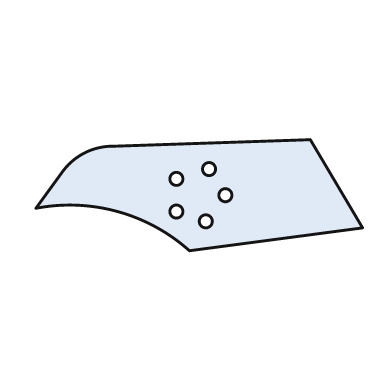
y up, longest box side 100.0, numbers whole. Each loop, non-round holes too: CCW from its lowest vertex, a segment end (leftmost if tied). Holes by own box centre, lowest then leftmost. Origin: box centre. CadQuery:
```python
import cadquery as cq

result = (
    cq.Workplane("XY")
    .moveTo(-3.0, -17.0)
    .lineTo(50.0, -10.0)
    .lineTo(34.0, 17.0)
    .lineTo(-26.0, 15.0)
    .threePointArc((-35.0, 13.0), (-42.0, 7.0))
    .lineTo(-50.0, -4.0)
    .threePointArc((-25.0, -5.0), (-3.0, -17.0))
    .close()
    .moveTo(2.0, -8.0)
    .circle(2.0)
    .moveTo(-7.0, -5.0)
    .circle(2.0)
    .moveTo(8.0, 0.0)
    .circle(2.0)
    .moveTo(-7.0, 5.0)
    .circle(2.0)
    .moveTo(3.0, 8.0)
    .circle(2.0)
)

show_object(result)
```